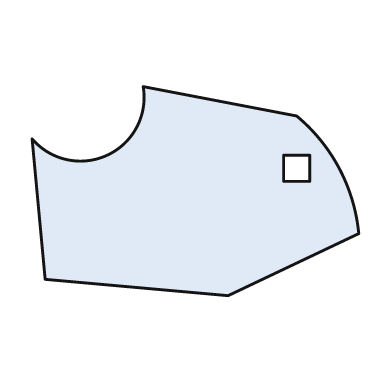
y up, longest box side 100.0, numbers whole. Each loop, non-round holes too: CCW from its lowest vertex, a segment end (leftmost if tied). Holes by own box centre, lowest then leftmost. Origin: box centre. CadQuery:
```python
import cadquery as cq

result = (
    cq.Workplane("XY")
    .moveTo(10.0, -32.0)
    .lineTo(50.0, -13.0)
    .threePointArc((44.0, 7.0), (31.0, 23.0))
    .lineTo(-16.0, 32.0)
    .threePointArc((-27.0, 11.0), (-50.0, 16.0))
    .lineTo(-46.0, -27.0)
    .close()
    .moveTo(27.0, 3.0)
    .lineTo(35.0, 3.0)
    .lineTo(35.0, 11.0)
    .lineTo(27.0, 11.0)
    .close()
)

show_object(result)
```